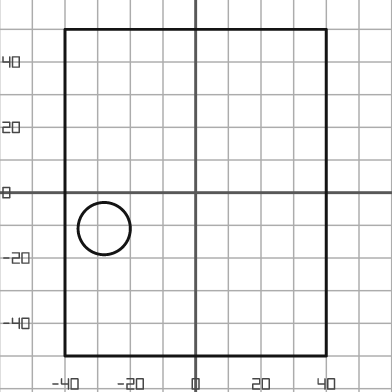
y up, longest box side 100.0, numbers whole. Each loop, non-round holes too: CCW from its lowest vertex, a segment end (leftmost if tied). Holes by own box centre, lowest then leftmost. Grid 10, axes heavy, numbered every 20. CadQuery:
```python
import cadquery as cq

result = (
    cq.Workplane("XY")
    .moveTo(-40.0, -50.0)
    .lineTo(40.0, -50.0)
    .lineTo(40.0, 50.0)
    .lineTo(-40.0, 50.0)
    .close()
    .moveTo(-28.0, -11.0)
    .circle(8.0)
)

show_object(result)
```